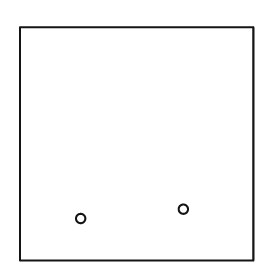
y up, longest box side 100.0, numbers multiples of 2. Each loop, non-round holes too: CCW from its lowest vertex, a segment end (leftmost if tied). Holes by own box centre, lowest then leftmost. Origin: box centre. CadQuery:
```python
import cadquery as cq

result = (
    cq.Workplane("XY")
    .moveTo(-50.0, -50.0)
    .lineTo(50.0, -50.0)
    .lineTo(50.0, 50.0)
    .lineTo(-50.0, 50.0)
    .close()
    .moveTo(-24.0, -32.0)
    .circle(2.0)
    .moveTo(20.0, -28.0)
    .circle(2.0)
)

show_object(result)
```